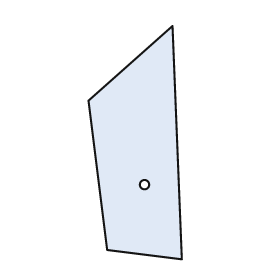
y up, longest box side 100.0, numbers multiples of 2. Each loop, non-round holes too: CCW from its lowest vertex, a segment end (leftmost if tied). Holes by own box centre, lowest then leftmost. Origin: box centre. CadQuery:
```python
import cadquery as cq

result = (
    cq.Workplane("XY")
    .moveTo(20.0, -50.0)
    .lineTo(16.0, 50.0)
    .lineTo(-20.0, 18.0)
    .lineTo(-12.0, -46.0)
    .close()
    .moveTo(4.0, -18.0)
    .circle(2.0)
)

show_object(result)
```